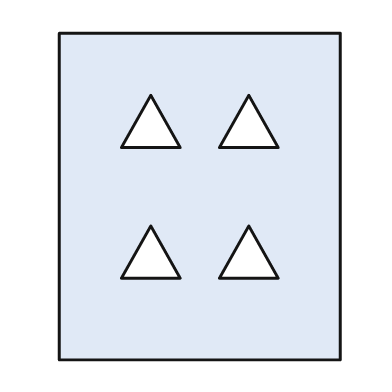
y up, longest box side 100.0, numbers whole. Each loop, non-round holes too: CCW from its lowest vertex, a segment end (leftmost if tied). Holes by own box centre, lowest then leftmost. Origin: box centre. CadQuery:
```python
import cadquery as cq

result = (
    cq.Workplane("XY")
    .moveTo(-43.0, -50.0)
    .lineTo(43.0, -50.0)
    .lineTo(43.0, 50.0)
    .lineTo(-43.0, 50.0)
    .close()
    .moveTo(-24.0, -25.0)
    .lineTo(-6.0, -25.0)
    .lineTo(-15.0, -9.0)
    .close()
    .moveTo(6.0, -25.0)
    .lineTo(24.0, -25.0)
    .lineTo(15.0, -9.0)
    .close()
    .moveTo(-24.0, 15.0)
    .lineTo(-6.0, 15.0)
    .lineTo(-15.0, 31.0)
    .close()
    .moveTo(6.0, 15.0)
    .lineTo(24.0, 15.0)
    .lineTo(15.0, 31.0)
    .close()
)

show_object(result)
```